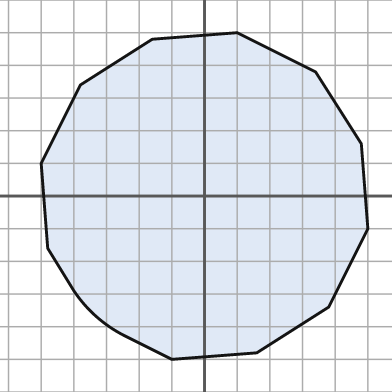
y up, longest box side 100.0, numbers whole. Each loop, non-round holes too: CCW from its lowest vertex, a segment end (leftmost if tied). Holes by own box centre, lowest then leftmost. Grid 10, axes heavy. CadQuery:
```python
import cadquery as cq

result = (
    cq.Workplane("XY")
    .moveTo(-10.0, -50.0)
    .lineTo(16.0, -48.0)
    .lineTo(38.0, -34.0)
    .lineTo(50.0, -10.0)
    .lineTo(48.0, 16.0)
    .lineTo(34.0, 38.0)
    .lineTo(10.0, 50.0)
    .lineTo(-16.0, 48.0)
    .lineTo(-38.0, 34.0)
    .lineTo(-50.0, 10.0)
    .lineTo(-48.0, -16.0)
    .lineTo(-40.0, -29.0)
    .threePointArc((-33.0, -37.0), (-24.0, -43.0))
    .close()
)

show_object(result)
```